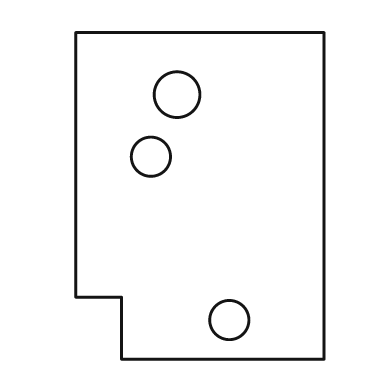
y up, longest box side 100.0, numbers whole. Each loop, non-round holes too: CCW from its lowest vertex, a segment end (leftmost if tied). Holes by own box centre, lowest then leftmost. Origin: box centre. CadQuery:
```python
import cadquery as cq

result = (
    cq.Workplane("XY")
    .moveTo(-24.0, -50.0)
    .lineTo(38.0, -50.0)
    .lineTo(38.0, 50.0)
    .lineTo(-38.0, 50.0)
    .lineTo(-38.0, -31.0)
    .lineTo(-24.0, -31.0)
    .close()
    .moveTo(9.0, -38.0)
    .circle(6.0)
    .moveTo(-15.0, 12.0)
    .circle(6.0)
    .moveTo(-7.0, 31.0)
    .circle(7.0)
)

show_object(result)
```